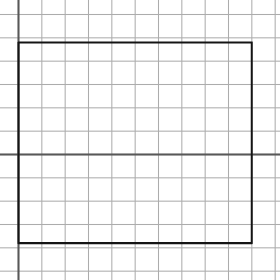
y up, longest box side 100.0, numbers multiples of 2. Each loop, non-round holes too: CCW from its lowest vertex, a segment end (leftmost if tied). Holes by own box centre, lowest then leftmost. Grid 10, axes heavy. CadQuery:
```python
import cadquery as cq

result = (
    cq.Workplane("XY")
    .moveTo(0.0, -38.0)
    .lineTo(100.0, -38.0)
    .lineTo(100.0, 48.0)
    .lineTo(0.0, 48.0)
    .close()
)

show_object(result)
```